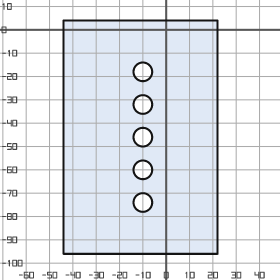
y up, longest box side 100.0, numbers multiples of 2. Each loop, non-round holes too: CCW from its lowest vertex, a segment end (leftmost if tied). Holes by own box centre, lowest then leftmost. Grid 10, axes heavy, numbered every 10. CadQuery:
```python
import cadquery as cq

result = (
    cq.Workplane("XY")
    .moveTo(-44.0, -96.0)
    .lineTo(22.0, -96.0)
    .lineTo(22.0, 4.0)
    .lineTo(-44.0, 4.0)
    .close()
    .moveTo(-10.0, -74.0)
    .circle(4.0)
    .moveTo(-10.0, -60.0)
    .circle(4.0)
    .moveTo(-10.0, -46.0)
    .circle(4.0)
    .moveTo(-10.0, -32.0)
    .circle(4.0)
    .moveTo(-10.0, -18.0)
    .circle(4.0)
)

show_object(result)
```